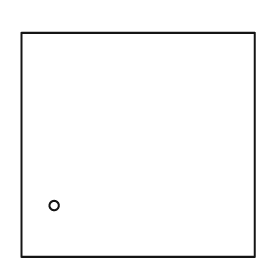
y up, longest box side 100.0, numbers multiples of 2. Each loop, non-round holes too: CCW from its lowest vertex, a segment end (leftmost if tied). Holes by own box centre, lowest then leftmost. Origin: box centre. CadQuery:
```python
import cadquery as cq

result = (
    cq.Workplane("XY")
    .moveTo(-50.0, -48.0)
    .lineTo(50.0, -48.0)
    .lineTo(50.0, 48.0)
    .lineTo(-50.0, 48.0)
    .close()
    .moveTo(-36.0, -26.0)
    .circle(2.0)
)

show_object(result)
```